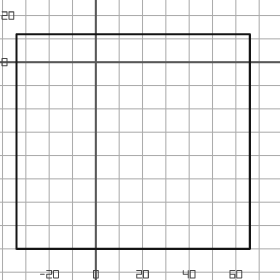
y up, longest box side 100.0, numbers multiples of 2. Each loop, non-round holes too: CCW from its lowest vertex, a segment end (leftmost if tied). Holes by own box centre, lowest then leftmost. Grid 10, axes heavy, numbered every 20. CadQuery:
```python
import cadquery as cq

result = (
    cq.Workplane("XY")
    .moveTo(-34.0, -80.0)
    .lineTo(66.0, -80.0)
    .lineTo(66.0, 12.0)
    .lineTo(-34.0, 12.0)
    .close()
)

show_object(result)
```